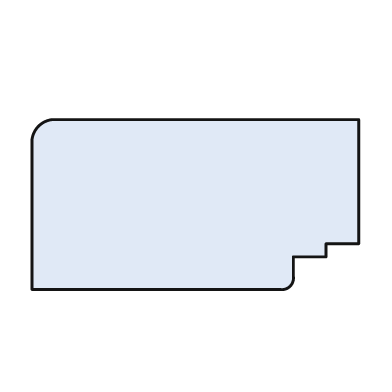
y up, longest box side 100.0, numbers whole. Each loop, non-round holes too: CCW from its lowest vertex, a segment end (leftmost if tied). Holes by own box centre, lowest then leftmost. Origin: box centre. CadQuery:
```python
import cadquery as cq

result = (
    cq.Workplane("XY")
    .moveTo(-50.0, -26.0)
    .lineTo(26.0, -26.0)
    .threePointArc((29.0, -25.0), (30.0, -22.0))
    .lineTo(30.0, -16.0)
    .lineTo(40.0, -16.0)
    .lineTo(40.0, -12.0)
    .lineTo(50.0, -12.0)
    .lineTo(50.0, 26.0)
    .lineTo(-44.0, 26.0)
    .threePointArc((-48.0, 24.0), (-50.0, 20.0))
    .close()
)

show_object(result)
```